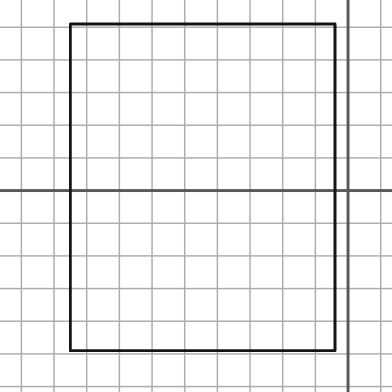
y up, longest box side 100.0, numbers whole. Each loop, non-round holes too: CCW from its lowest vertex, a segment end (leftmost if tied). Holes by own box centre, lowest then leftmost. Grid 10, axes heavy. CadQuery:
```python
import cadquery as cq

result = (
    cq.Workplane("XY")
    .moveTo(-85.0, -49.0)
    .lineTo(-4.0, -49.0)
    .lineTo(-4.0, 51.0)
    .lineTo(-85.0, 51.0)
    .close()
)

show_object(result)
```